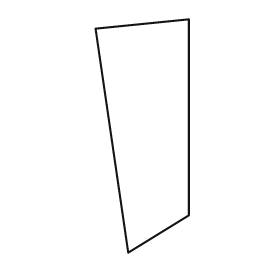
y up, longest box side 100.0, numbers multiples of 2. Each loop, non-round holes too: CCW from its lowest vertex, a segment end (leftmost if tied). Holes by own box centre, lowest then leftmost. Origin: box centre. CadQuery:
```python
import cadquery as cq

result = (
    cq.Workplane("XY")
    .moveTo(-6.0, -50.0)
    .lineTo(20.0, -34.0)
    .lineTo(20.0, 50.0)
    .lineTo(-20.0, 46.0)
    .close()
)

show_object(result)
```